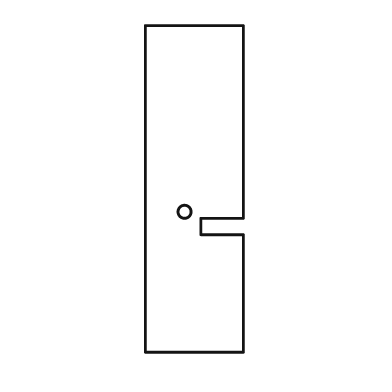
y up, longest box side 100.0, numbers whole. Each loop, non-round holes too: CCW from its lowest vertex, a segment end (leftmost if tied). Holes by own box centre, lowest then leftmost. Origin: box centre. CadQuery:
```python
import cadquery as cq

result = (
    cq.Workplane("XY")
    .moveTo(-15.0, -50.0)
    .lineTo(15.0, -50.0)
    .lineTo(15.0, -14.0)
    .lineTo(2.0, -14.0)
    .lineTo(2.0, -9.0)
    .lineTo(15.0, -9.0)
    .lineTo(15.0, 50.0)
    .lineTo(-15.0, 50.0)
    .close()
    .moveTo(-3.0, -7.0)
    .circle(2.0)
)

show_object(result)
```